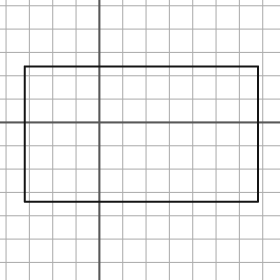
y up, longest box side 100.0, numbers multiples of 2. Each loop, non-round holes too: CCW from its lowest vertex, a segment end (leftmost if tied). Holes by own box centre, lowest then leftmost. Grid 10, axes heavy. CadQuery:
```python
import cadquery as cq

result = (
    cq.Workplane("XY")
    .moveTo(-32.0, -34.0)
    .lineTo(68.0, -34.0)
    .lineTo(68.0, 24.0)
    .lineTo(-32.0, 24.0)
    .close()
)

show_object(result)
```